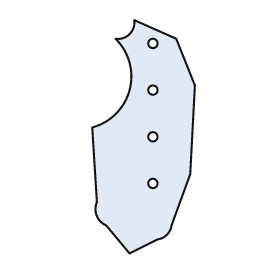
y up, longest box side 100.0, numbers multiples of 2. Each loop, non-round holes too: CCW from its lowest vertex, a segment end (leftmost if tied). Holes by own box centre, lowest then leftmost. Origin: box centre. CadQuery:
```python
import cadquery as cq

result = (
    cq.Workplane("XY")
    .moveTo(-6.0, -50.0)
    .lineTo(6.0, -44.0)
    .threePointArc((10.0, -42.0), (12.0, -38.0))
    .lineTo(20.0, -16.0)
    .lineTo(22.0, 22.0)
    .lineTo(14.0, 42.0)
    .lineTo(-4.0, 50.0)
    .threePointArc((-6.0, 44.0), (-12.0, 42.0))
    .threePointArc((-6.0, 20.0), (-22.0, 4.0))
    .lineTo(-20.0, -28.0)
    .threePointArc((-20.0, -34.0), (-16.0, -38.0))
    .close()
    .moveTo(4.0, -20.0)
    .circle(2.0)
    .moveTo(4.0, 0.0)
    .circle(2.0)
    .moveTo(4.0, 20.0)
    .circle(2.0)
    .moveTo(4.0, 40.0)
    .circle(2.0)
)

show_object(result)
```